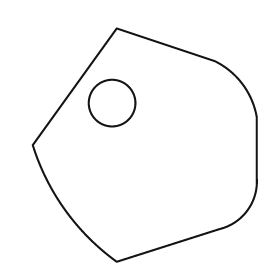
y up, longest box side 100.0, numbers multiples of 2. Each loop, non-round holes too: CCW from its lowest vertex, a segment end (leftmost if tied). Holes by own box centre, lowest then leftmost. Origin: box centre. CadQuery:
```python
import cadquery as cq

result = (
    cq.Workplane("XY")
    .moveTo(-12.0, -50.0)
    .lineTo(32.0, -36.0)
    .threePointArc((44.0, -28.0), (48.0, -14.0))
    .lineTo(48.0, 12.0)
    .threePointArc((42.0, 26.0), (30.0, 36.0))
    .lineTo(-12.0, 50.0)
    .lineTo(-48.0, 0.0)
    .threePointArc((-34.0, -28.0), (-12.0, -50.0))
    .close()
    .moveTo(-14.0, 18.0)
    .circle(10.0)
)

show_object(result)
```